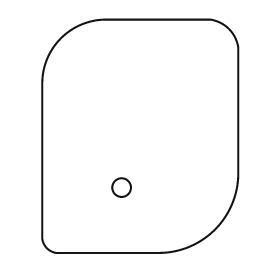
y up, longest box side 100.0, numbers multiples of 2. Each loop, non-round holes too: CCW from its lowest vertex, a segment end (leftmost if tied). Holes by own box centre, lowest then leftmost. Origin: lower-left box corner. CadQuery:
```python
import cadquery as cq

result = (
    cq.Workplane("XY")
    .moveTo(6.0, 0.0)
    .lineTo(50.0, 0.0)
    .threePointArc((74.0, 10.0), (84.0, 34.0))
    .lineTo(84.0, 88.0)
    .threePointArc((80.0, 96.0), (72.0, 100.0))
    .lineTo(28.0, 100.0)
    .threePointArc((8.0, 92.0), (0.0, 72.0))
    .lineTo(0.0, 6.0)
    .threePointArc((2.0, 2.0), (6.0, 0.0))
    .close()
    .moveTo(34.0, 28.0)
    .circle(4.0)
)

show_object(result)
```